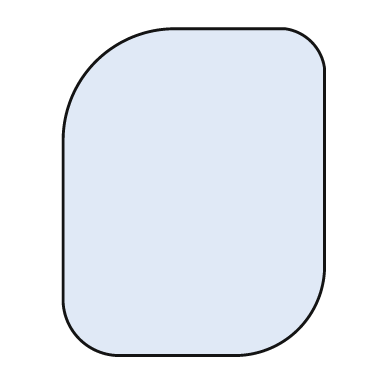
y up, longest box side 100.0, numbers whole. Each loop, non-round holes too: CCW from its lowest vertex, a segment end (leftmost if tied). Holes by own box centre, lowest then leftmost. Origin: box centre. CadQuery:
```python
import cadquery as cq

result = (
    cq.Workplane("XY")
    .moveTo(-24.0, -50.0)
    .lineTo(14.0, -50.0)
    .threePointArc((32.0, -42.0), (40.0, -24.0))
    .lineTo(40.0, 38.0)
    .threePointArc((36.0, 46.0), (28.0, 50.0))
    .lineTo(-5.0, 50.0)
    .threePointArc((-30.0, 40.0), (-40.0, 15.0))
    .lineTo(-40.0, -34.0)
    .threePointArc((-35.0, -45.0), (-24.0, -50.0))
    .close()
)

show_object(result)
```